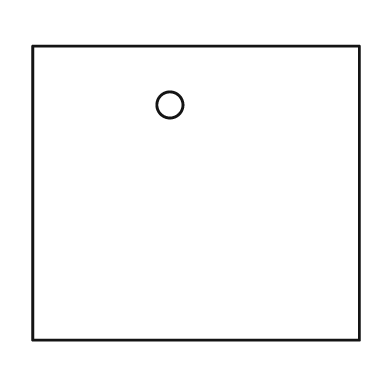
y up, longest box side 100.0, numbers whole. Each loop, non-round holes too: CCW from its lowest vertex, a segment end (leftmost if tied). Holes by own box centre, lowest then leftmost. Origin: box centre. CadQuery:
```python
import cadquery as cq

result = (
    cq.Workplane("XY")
    .moveTo(-50.0, -45.0)
    .lineTo(50.0, -45.0)
    .lineTo(50.0, 45.0)
    .lineTo(-50.0, 45.0)
    .close()
    .moveTo(-8.0, 27.0)
    .circle(4.0)
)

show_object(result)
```